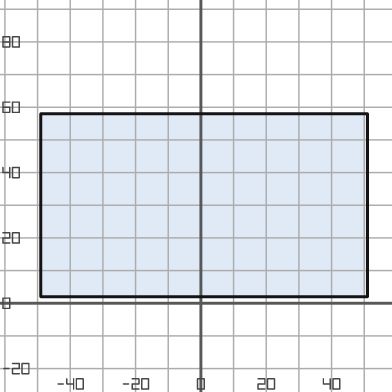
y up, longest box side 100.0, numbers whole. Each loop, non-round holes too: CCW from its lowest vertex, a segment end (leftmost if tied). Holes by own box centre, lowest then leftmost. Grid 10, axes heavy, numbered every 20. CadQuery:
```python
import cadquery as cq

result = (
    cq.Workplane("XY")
    .moveTo(-49.0, 2.0)
    .lineTo(51.0, 2.0)
    .lineTo(51.0, 58.0)
    .lineTo(-49.0, 58.0)
    .close()
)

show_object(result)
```